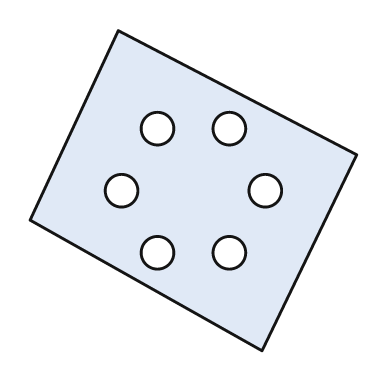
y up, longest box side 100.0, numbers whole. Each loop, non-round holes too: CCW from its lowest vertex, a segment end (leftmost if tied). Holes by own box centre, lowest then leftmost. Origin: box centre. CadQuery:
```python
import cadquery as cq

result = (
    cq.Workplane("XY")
    .moveTo(21.0, -49.0)
    .lineTo(50.0, 11.0)
    .lineTo(-23.0, 49.0)
    .lineTo(-50.0, -9.0)
    .close()
    .moveTo(-11.0, -19.0)
    .circle(5.0)
    .moveTo(11.0, -19.0)
    .circle(5.0)
    .moveTo(-22.0, 0.0)
    .circle(5.0)
    .moveTo(22.0, 0.0)
    .circle(5.0)
    .moveTo(-11.0, 19.0)
    .circle(5.0)
    .moveTo(11.0, 19.0)
    .circle(5.0)
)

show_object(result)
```